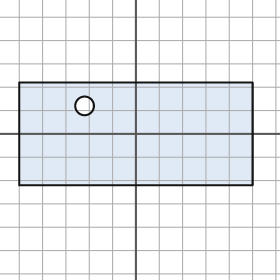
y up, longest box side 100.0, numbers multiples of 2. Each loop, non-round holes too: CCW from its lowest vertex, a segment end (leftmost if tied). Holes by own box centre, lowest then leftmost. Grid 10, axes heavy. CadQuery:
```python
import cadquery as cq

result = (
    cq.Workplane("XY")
    .moveTo(-50.0, -22.0)
    .lineTo(50.0, -22.0)
    .lineTo(50.0, 22.0)
    .lineTo(-50.0, 22.0)
    .close()
    .moveTo(-22.0, 12.0)
    .circle(4.0)
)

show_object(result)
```